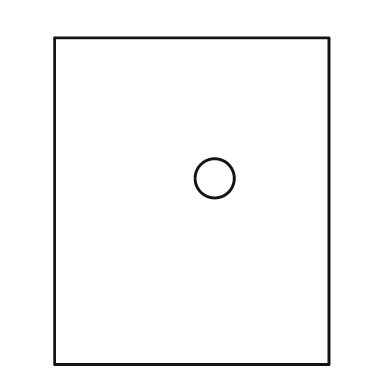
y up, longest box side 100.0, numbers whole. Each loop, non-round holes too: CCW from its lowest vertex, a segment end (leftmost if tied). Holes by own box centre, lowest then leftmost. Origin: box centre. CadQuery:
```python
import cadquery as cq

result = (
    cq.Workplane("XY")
    .moveTo(-42.0, -50.0)
    .lineTo(42.0, -50.0)
    .lineTo(42.0, 50.0)
    .lineTo(-42.0, 50.0)
    .close()
    .moveTo(7.0, 7.0)
    .circle(6.0)
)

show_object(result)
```